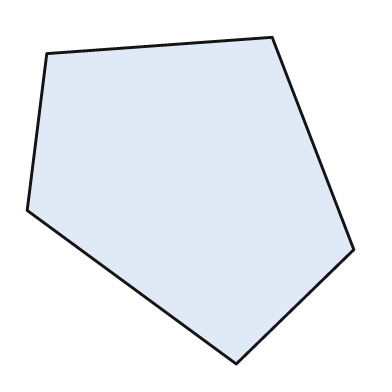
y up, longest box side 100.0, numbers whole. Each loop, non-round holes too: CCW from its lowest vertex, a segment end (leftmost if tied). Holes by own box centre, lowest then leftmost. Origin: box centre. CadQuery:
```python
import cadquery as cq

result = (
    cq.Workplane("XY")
    .moveTo(14.0, -50.0)
    .lineTo(50.0, -15.0)
    .lineTo(25.0, 50.0)
    .lineTo(-44.0, 45.0)
    .lineTo(-50.0, -3.0)
    .close()
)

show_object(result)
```